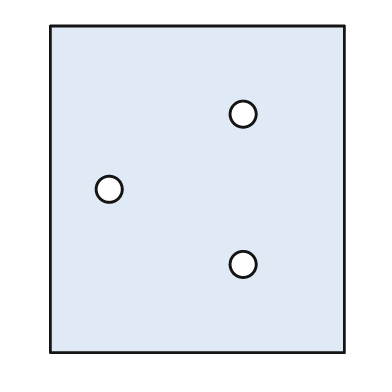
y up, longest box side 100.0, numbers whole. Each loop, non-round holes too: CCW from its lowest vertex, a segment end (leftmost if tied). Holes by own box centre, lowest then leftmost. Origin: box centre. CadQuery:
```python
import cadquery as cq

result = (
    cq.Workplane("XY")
    .moveTo(-45.0, -50.0)
    .lineTo(45.0, -50.0)
    .lineTo(45.0, 50.0)
    .lineTo(-45.0, 50.0)
    .close()
    .moveTo(14.0, -23.0)
    .circle(4.0)
    .moveTo(-27.0, 0.0)
    .circle(4.0)
    .moveTo(14.0, 23.0)
    .circle(4.0)
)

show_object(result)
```